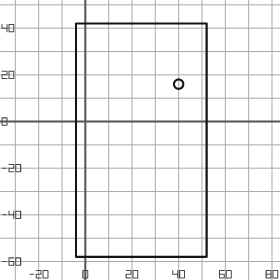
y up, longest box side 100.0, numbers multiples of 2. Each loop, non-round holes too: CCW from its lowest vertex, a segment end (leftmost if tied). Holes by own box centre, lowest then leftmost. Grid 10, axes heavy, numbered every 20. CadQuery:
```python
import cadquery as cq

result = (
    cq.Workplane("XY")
    .moveTo(-4.0, -58.0)
    .lineTo(52.0, -58.0)
    .lineTo(52.0, 42.0)
    .lineTo(-4.0, 42.0)
    .close()
    .moveTo(40.0, 16.0)
    .circle(2.0)
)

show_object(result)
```